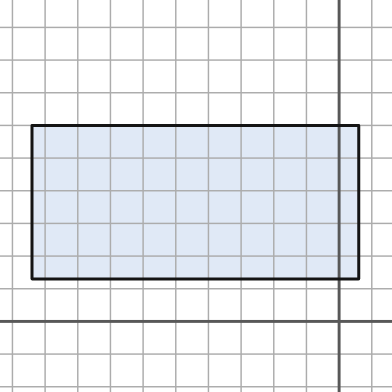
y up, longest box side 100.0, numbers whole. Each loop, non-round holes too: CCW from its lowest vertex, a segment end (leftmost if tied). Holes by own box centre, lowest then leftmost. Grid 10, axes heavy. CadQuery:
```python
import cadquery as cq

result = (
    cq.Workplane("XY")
    .moveTo(-94.0, 13.0)
    .lineTo(6.0, 13.0)
    .lineTo(6.0, 60.0)
    .lineTo(-94.0, 60.0)
    .close()
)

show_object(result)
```